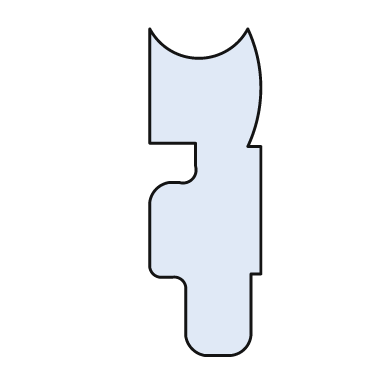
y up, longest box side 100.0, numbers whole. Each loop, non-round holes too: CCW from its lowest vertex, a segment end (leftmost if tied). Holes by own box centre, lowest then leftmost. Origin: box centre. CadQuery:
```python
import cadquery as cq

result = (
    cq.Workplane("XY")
    .moveTo(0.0, -50.0)
    .lineTo(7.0, -50.0)
    .threePointArc((12.0, -48.0), (14.0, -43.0))
    .lineTo(14.0, -25.0)
    .lineTo(17.0, -25.0)
    .lineTo(17.0, 14.0)
    .lineTo(13.0, 14.0)
    .threePointArc((17.0, 32.0), (13.0, 50.0))
    .threePointArc((-2.0, 41.0), (-17.0, 50.0))
    .lineTo(-17.0, 15.0)
    .lineTo(-3.0, 15.0)
    .lineTo(-3.0, 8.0)
    .threePointArc((-4.0, 4.0), (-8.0, 3.0))
    .lineTo(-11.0, 3.0)
    .threePointArc((-15.0, 1.0), (-17.0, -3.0))
    .lineTo(-17.0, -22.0)
    .threePointArc((-16.0, -25.0), (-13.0, -26.0))
    .lineTo(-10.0, -26.0)
    .threePointArc((-7.0, -27.0), (-6.0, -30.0))
    .lineTo(-6.0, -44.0)
    .threePointArc((-4.0, -48.0), (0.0, -50.0))
    .close()
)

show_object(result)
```